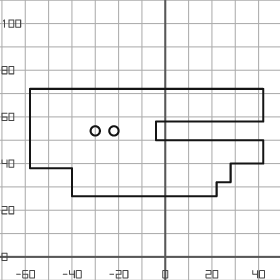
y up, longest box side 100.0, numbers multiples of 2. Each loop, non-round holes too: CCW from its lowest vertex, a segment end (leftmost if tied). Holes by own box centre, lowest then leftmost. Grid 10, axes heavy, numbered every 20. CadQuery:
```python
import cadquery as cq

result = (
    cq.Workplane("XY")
    .moveTo(-40.0, 26.0)
    .lineTo(22.0, 26.0)
    .lineTo(22.0, 32.0)
    .lineTo(28.0, 32.0)
    .lineTo(28.0, 40.0)
    .lineTo(42.0, 40.0)
    .lineTo(42.0, 50.0)
    .lineTo(-4.0, 50.0)
    .lineTo(-4.0, 58.0)
    .lineTo(42.0, 58.0)
    .lineTo(42.0, 72.0)
    .lineTo(-58.0, 72.0)
    .lineTo(-58.0, 38.0)
    .lineTo(-40.0, 38.0)
    .close()
    .moveTo(-30.0, 54.0)
    .circle(2.0)
    .moveTo(-22.0, 54.0)
    .circle(2.0)
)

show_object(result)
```